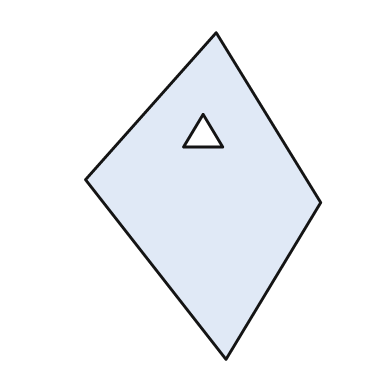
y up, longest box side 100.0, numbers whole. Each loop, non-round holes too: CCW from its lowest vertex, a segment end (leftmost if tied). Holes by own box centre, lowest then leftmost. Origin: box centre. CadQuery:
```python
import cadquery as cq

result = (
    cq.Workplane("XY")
    .moveTo(7.0, -50.0)
    .lineTo(36.0, -2.0)
    .lineTo(4.0, 50.0)
    .lineTo(-36.0, 5.0)
    .close()
    .moveTo(-6.0, 15.0)
    .lineTo(6.0, 15.0)
    .lineTo(0.0, 25.0)
    .close()
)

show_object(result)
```